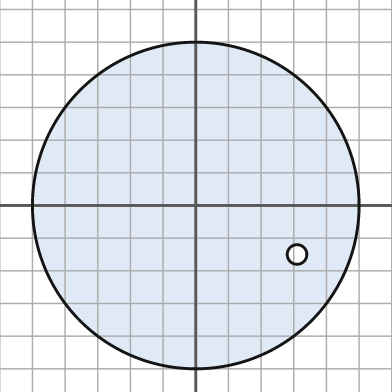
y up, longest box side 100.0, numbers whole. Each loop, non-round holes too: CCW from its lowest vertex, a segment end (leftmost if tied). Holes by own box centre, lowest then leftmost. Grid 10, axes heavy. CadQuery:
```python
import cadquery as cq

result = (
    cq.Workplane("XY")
    .moveTo(0.0, 0.0)
    .circle(50.0)
    .moveTo(31.0, -15.0)
    .circle(3.0)
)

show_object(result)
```